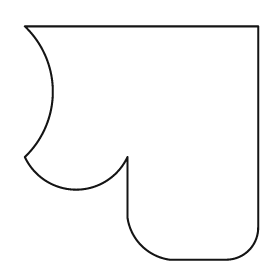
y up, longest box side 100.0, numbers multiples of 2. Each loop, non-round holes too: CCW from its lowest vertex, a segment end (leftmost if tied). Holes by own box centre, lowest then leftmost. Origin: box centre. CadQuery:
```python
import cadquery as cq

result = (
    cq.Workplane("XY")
    .moveTo(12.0, -50.0)
    .lineTo(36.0, -50.0)
    .threePointArc((46.0, -46.0), (50.0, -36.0))
    .lineTo(50.0, 50.0)
    .lineTo(-50.0, 50.0)
    .threePointArc((-38.0, 22.0), (-50.0, -6.0))
    .threePointArc((-28.0, -20.0), (-6.0, -6.0))
    .lineTo(-6.0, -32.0)
    .threePointArc((0.0, -44.0), (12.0, -50.0))
    .close()
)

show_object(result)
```